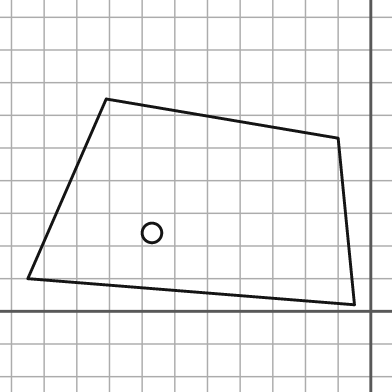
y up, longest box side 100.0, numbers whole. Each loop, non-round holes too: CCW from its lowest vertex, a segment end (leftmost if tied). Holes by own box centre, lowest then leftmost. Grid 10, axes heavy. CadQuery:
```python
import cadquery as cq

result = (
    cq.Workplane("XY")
    .moveTo(-5.0, 2.0)
    .lineTo(-10.0, 53.0)
    .lineTo(-81.0, 65.0)
    .lineTo(-105.0, 10.0)
    .close()
    .moveTo(-67.0, 24.0)
    .circle(3.0)
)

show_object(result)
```